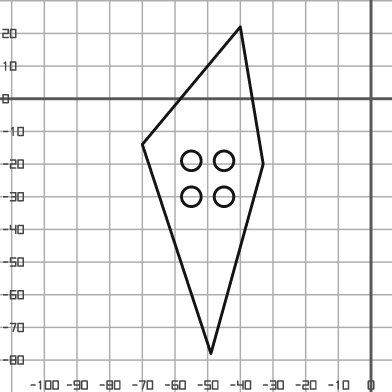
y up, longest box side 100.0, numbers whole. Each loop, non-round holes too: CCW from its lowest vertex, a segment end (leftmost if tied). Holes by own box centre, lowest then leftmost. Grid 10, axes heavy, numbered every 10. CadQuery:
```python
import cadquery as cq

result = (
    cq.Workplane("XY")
    .moveTo(-49.0, -78.0)
    .lineTo(-33.0, -20.0)
    .lineTo(-40.0, 22.0)
    .lineTo(-70.0, -14.0)
    .close()
    .moveTo(-55.0, -30.0)
    .circle(3.0)
    .moveTo(-45.0, -30.0)
    .circle(3.0)
    .moveTo(-55.0, -19.0)
    .circle(3.0)
    .moveTo(-45.0, -19.0)
    .circle(3.0)
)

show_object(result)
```